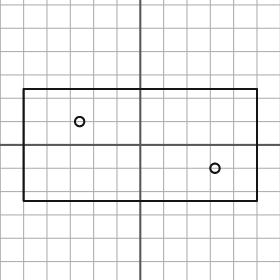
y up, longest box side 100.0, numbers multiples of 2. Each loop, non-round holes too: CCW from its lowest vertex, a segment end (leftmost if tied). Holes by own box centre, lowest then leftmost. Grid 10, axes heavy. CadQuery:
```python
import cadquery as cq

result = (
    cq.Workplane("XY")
    .moveTo(-50.0, -24.0)
    .lineTo(50.0, -24.0)
    .lineTo(50.0, 24.0)
    .lineTo(-50.0, 24.0)
    .close()
    .moveTo(32.0, -10.0)
    .circle(2.0)
    .moveTo(-26.0, 10.0)
    .circle(2.0)
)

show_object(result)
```